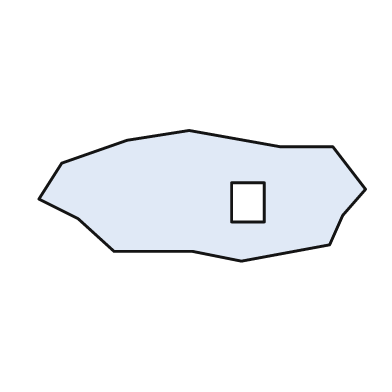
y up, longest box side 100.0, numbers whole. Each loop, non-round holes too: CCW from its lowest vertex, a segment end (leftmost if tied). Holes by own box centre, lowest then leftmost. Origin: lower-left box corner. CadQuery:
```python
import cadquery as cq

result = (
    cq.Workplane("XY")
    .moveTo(62.0, 0.0)
    .lineTo(89.0, 5.0)
    .lineTo(93.0, 14.0)
    .lineTo(100.0, 22.0)
    .lineTo(90.0, 35.0)
    .lineTo(74.0, 35.0)
    .lineTo(46.0, 40.0)
    .lineTo(27.0, 37.0)
    .lineTo(7.0, 30.0)
    .lineTo(0.0, 19.0)
    .lineTo(12.0, 13.0)
    .lineTo(23.0, 3.0)
    .lineTo(47.0, 3.0)
    .close()
    .moveTo(59.0, 12.0)
    .lineTo(69.0, 12.0)
    .lineTo(69.0, 24.0)
    .lineTo(59.0, 24.0)
    .close()
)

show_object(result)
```